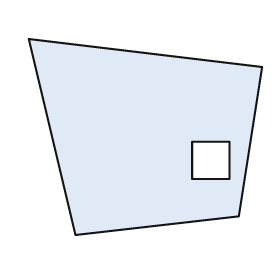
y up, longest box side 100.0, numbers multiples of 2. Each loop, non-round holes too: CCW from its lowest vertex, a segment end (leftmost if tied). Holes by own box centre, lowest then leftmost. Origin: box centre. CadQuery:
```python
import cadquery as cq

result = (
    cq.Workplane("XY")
    .moveTo(-30.0, -42.0)
    .lineTo(40.0, -34.0)
    .lineTo(50.0, 30.0)
    .lineTo(-50.0, 42.0)
    .close()
    .moveTo(20.0, -18.0)
    .lineTo(36.0, -18.0)
    .lineTo(36.0, -2.0)
    .lineTo(20.0, -2.0)
    .close()
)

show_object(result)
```